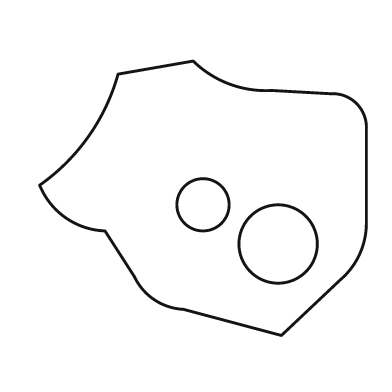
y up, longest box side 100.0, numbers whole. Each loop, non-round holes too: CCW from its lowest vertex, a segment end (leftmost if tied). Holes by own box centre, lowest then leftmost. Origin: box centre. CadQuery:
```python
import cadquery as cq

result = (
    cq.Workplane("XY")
    .moveTo(24.0, -42.0)
    .lineTo(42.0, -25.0)
    .threePointArc((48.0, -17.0), (50.0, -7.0))
    .lineTo(50.0, 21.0)
    .threePointArc((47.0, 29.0), (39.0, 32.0))
    .lineTo(21.0, 33.0)
    .threePointArc((8.0, 35.0), (-3.0, 42.0))
    .lineTo(-26.0, 38.0)
    .threePointArc((-35.0, 19.0), (-50.0, 4.0))
    .threePointArc((-42.0, -6.0), (-30.0, -10.0))
    .lineTo(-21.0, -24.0)
    .threePointArc((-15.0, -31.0), (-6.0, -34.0))
    .close()
    .moveTo(23.0, -14.0)
    .circle(12.0)
    .moveTo(0.0, -2.0)
    .circle(8.0)
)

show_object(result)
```